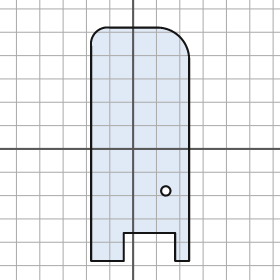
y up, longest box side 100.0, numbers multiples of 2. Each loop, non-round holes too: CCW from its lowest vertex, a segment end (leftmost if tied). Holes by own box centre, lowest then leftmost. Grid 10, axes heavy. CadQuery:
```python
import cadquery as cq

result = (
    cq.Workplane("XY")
    .moveTo(-18.0, -48.0)
    .lineTo(-4.0, -48.0)
    .lineTo(-4.0, -36.0)
    .lineTo(18.0, -36.0)
    .lineTo(18.0, -48.0)
    .lineTo(24.0, -48.0)
    .lineTo(24.0, 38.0)
    .threePointArc((20.0, 48.0), (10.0, 52.0))
    .lineTo(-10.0, 52.0)
    .threePointArc((-16.0, 50.0), (-18.0, 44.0))
    .close()
    .moveTo(14.0, -18.0)
    .circle(2.0)
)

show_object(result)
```